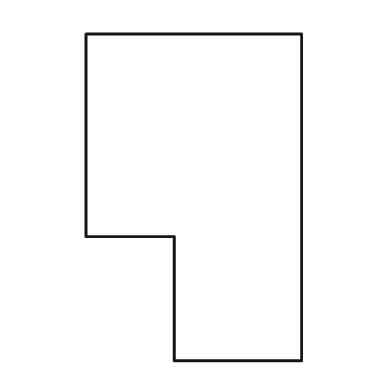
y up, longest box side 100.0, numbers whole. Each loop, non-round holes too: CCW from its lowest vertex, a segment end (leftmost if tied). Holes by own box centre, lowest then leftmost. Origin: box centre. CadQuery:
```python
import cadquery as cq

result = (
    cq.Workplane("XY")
    .moveTo(-6.0, -50.0)
    .lineTo(33.0, -50.0)
    .lineTo(33.0, 50.0)
    .lineTo(-33.0, 50.0)
    .lineTo(-33.0, -12.0)
    .lineTo(-6.0, -12.0)
    .close()
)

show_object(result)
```